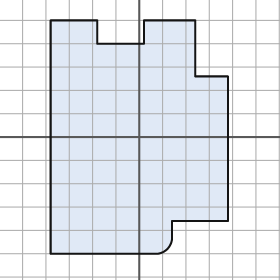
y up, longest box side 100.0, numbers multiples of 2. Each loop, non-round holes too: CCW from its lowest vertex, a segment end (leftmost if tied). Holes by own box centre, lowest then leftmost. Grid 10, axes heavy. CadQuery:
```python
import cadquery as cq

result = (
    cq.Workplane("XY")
    .moveTo(-38.0, -50.0)
    .lineTo(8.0, -50.0)
    .threePointArc((12.0, -48.0), (14.0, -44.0))
    .lineTo(14.0, -36.0)
    .lineTo(38.0, -36.0)
    .lineTo(38.0, 26.0)
    .lineTo(24.0, 26.0)
    .lineTo(24.0, 50.0)
    .lineTo(2.0, 50.0)
    .lineTo(2.0, 40.0)
    .lineTo(-18.0, 40.0)
    .lineTo(-18.0, 50.0)
    .lineTo(-38.0, 50.0)
    .close()
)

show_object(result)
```